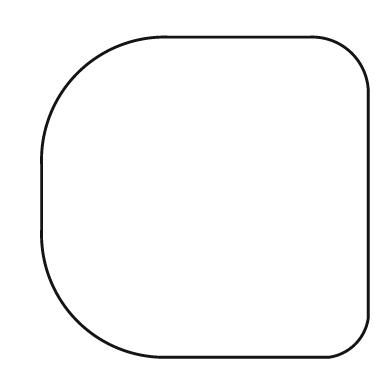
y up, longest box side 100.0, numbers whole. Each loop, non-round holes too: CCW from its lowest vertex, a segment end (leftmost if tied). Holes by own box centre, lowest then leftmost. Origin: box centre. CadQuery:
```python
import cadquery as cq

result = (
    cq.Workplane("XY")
    .moveTo(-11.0, -49.0)
    .lineTo(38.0, -49.0)
    .threePointArc((46.0, -45.0), (50.0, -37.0))
    .lineTo(50.0, 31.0)
    .threePointArc((45.0, 44.0), (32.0, 49.0))
    .lineTo(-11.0, 49.0)
    .threePointArc((-39.0, 38.0), (-50.0, 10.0))
    .lineTo(-50.0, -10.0)
    .threePointArc((-39.0, -38.0), (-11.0, -49.0))
    .close()
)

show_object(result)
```